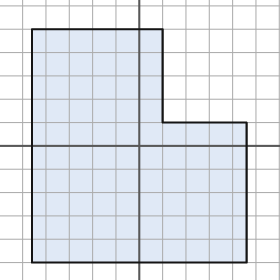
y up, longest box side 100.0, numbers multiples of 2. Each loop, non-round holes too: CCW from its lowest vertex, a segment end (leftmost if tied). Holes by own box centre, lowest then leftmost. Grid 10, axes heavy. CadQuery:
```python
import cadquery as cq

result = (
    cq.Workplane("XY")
    .moveTo(-46.0, -50.0)
    .lineTo(46.0, -50.0)
    .lineTo(46.0, 10.0)
    .lineTo(10.0, 10.0)
    .lineTo(10.0, 50.0)
    .lineTo(-46.0, 50.0)
    .close()
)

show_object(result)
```